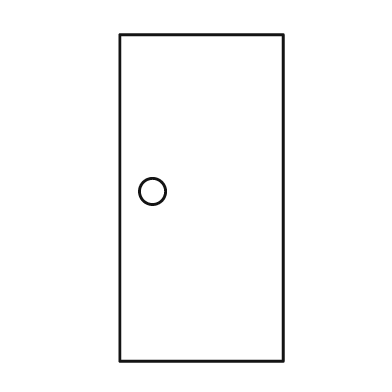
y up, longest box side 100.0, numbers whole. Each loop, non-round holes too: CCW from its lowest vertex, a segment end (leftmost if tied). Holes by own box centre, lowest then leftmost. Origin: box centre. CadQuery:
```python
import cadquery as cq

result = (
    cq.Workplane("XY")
    .moveTo(-25.0, -50.0)
    .lineTo(25.0, -50.0)
    .lineTo(25.0, 50.0)
    .lineTo(-25.0, 50.0)
    .close()
    .moveTo(-15.0, 2.0)
    .circle(4.0)
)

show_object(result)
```